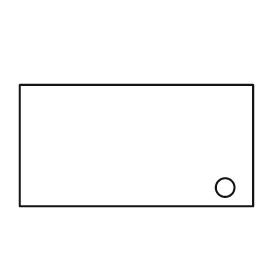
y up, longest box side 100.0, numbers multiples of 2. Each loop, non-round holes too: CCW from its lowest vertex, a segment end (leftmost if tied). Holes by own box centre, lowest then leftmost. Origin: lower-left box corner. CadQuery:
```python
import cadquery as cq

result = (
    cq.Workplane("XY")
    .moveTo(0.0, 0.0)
    .lineTo(100.0, 0.0)
    .lineTo(100.0, 52.0)
    .lineTo(0.0, 52.0)
    .close()
    .moveTo(88.0, 8.0)
    .circle(4.0)
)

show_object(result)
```